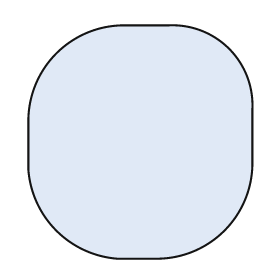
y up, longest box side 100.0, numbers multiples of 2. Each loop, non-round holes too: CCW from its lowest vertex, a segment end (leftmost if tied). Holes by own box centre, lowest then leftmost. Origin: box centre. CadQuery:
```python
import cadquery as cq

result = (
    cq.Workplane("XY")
    .moveTo(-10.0, -50.0)
    .lineTo(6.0, -50.0)
    .threePointArc((36.0, -38.0), (48.0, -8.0))
    .lineTo(48.0, 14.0)
    .threePointArc((38.0, 40.0), (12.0, 50.0))
    .lineTo(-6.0, 50.0)
    .threePointArc((-36.0, 38.0), (-48.0, 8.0))
    .lineTo(-48.0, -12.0)
    .threePointArc((-36.0, -38.0), (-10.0, -50.0))
    .close()
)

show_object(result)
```